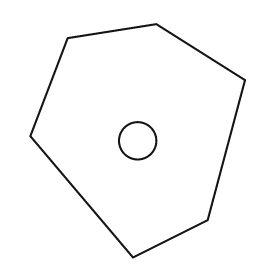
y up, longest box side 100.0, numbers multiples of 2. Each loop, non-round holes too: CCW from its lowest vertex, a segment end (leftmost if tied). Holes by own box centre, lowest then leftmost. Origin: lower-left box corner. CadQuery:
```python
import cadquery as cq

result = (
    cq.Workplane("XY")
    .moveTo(44.0, 0.0)
    .lineTo(76.0, 16.0)
    .lineTo(92.0, 76.0)
    .lineTo(54.0, 100.0)
    .lineTo(16.0, 94.0)
    .lineTo(0.0, 52.0)
    .close()
    .moveTo(46.0, 50.0)
    .circle(8.0)
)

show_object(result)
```